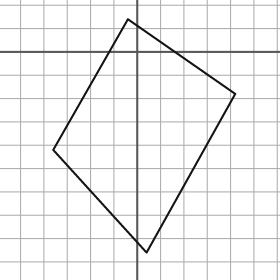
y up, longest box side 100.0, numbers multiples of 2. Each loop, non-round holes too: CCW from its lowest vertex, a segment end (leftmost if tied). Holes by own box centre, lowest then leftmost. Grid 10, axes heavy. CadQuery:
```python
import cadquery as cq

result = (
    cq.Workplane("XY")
    .moveTo(4.0, -86.0)
    .lineTo(42.0, -18.0)
    .lineTo(-4.0, 14.0)
    .lineTo(-36.0, -42.0)
    .close()
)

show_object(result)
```